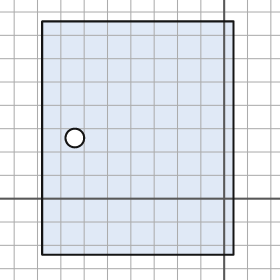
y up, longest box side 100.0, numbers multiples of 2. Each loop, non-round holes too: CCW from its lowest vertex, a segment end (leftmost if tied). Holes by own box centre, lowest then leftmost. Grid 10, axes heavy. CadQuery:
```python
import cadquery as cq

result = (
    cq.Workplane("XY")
    .moveTo(-78.0, -24.0)
    .lineTo(4.0, -24.0)
    .lineTo(4.0, 76.0)
    .lineTo(-78.0, 76.0)
    .close()
    .moveTo(-64.0, 26.0)
    .circle(4.0)
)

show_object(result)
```